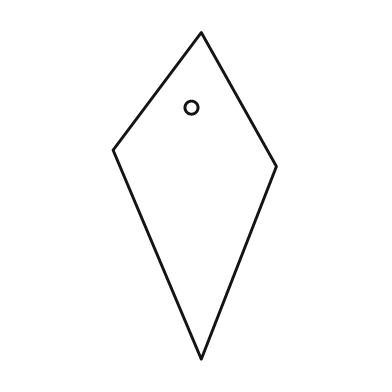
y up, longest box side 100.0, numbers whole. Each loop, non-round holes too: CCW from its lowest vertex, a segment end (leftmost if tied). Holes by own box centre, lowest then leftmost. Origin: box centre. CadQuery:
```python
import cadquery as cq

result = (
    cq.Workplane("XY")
    .moveTo(2.0, -50.0)
    .lineTo(25.0, 9.0)
    .lineTo(2.0, 50.0)
    .lineTo(-25.0, 14.0)
    .close()
    .moveTo(-1.0, 27.0)
    .circle(2.0)
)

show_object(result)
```